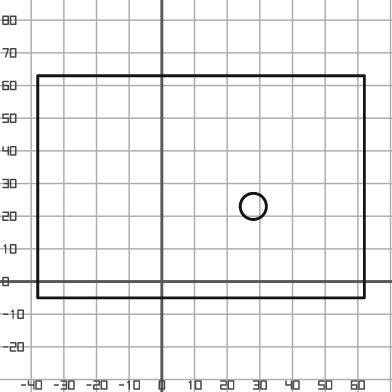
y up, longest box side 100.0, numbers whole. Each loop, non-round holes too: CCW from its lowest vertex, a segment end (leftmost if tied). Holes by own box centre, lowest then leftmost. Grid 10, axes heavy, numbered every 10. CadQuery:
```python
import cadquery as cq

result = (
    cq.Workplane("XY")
    .moveTo(-38.0, -5.0)
    .lineTo(62.0, -5.0)
    .lineTo(62.0, 63.0)
    .lineTo(-38.0, 63.0)
    .close()
    .moveTo(28.0, 23.0)
    .circle(4.0)
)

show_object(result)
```